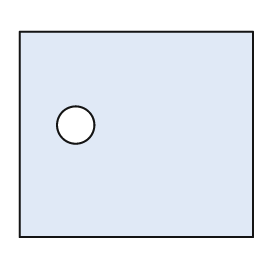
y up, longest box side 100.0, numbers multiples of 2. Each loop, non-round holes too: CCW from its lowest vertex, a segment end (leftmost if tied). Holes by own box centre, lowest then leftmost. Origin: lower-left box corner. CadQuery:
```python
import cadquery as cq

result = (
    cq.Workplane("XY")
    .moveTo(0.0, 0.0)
    .lineTo(100.0, 0.0)
    .lineTo(100.0, 88.0)
    .lineTo(0.0, 88.0)
    .close()
    .moveTo(24.0, 48.0)
    .circle(8.0)
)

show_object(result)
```